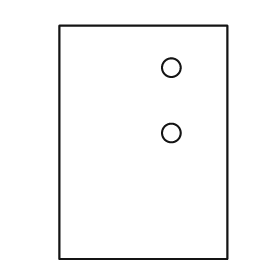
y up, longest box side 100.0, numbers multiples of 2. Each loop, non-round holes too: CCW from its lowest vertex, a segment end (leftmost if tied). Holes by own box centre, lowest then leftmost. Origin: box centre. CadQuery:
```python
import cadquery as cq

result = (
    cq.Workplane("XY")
    .moveTo(-36.0, -50.0)
    .lineTo(36.0, -50.0)
    .lineTo(36.0, 50.0)
    .lineTo(-36.0, 50.0)
    .close()
    .moveTo(12.0, 4.0)
    .circle(4.0)
    .moveTo(12.0, 32.0)
    .circle(4.0)
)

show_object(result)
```